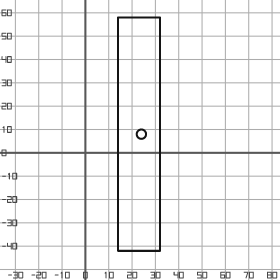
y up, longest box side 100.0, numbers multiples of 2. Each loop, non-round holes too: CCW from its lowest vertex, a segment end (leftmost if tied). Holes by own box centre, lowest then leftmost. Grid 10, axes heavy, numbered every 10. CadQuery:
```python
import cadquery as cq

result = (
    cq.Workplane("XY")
    .moveTo(14.0, -42.0)
    .lineTo(32.0, -42.0)
    .lineTo(32.0, 58.0)
    .lineTo(14.0, 58.0)
    .close()
    .moveTo(24.0, 8.0)
    .circle(2.0)
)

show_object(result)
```